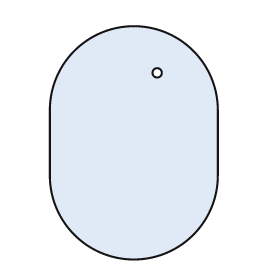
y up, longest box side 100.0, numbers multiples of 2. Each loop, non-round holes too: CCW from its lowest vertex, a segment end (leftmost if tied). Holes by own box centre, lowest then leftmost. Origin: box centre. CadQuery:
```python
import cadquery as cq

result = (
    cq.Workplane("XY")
    .moveTo(-36.0, -14.0)
    .threePointArc((0.0, -50.0), (36.0, -14.0))
    .lineTo(36.0, 14.0)
    .threePointArc((0.0, 50.0), (-36.0, 14.0))
    .close()
    .moveTo(10.0, 30.0)
    .circle(2.0)
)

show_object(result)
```